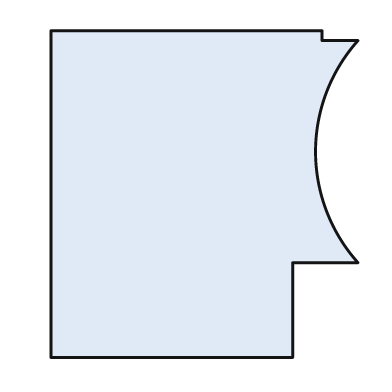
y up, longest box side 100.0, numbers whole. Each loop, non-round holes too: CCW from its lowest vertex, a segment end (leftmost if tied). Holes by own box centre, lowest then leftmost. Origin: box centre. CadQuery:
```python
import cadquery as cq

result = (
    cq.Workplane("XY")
    .moveTo(-47.0, -50.0)
    .lineTo(27.0, -50.0)
    .lineTo(27.0, -21.0)
    .lineTo(47.0, -21.0)
    .threePointArc((34.0, 13.0), (47.0, 47.0))
    .lineTo(36.0, 47.0)
    .lineTo(36.0, 50.0)
    .lineTo(-47.0, 50.0)
    .close()
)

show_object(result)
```